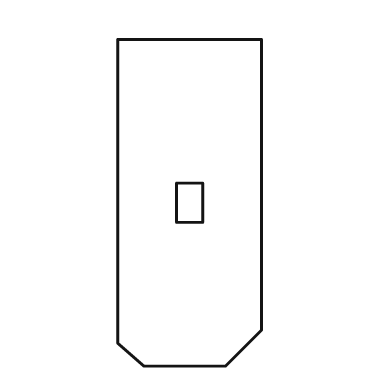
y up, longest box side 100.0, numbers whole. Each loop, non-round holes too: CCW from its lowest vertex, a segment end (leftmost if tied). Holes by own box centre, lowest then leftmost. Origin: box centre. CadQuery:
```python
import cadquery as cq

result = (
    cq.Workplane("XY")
    .moveTo(-14.0, -50.0)
    .lineTo(11.0, -50.0)
    .lineTo(22.0, -39.0)
    .lineTo(22.0, 50.0)
    .lineTo(-22.0, 50.0)
    .lineTo(-22.0, -43.0)
    .close()
    .moveTo(-4.0, -6.0)
    .lineTo(4.0, -6.0)
    .lineTo(4.0, 6.0)
    .lineTo(-4.0, 6.0)
    .close()
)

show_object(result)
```